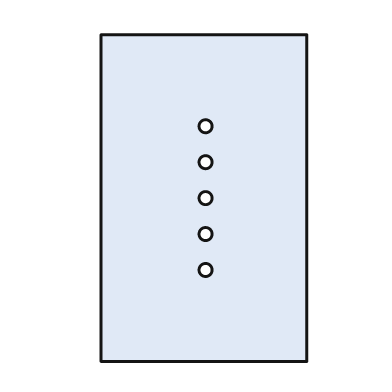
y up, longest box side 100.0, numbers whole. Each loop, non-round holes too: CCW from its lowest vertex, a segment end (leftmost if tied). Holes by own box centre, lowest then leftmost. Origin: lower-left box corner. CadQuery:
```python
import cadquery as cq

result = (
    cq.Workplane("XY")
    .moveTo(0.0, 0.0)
    .lineTo(63.0, 0.0)
    .lineTo(63.0, 100.0)
    .lineTo(0.0, 100.0)
    .close()
    .moveTo(32.0, 28.0)
    .circle(2.0)
    .moveTo(32.0, 39.0)
    .circle(2.0)
    .moveTo(32.0, 50.0)
    .circle(2.0)
    .moveTo(32.0, 61.0)
    .circle(2.0)
    .moveTo(32.0, 72.0)
    .circle(2.0)
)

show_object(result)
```